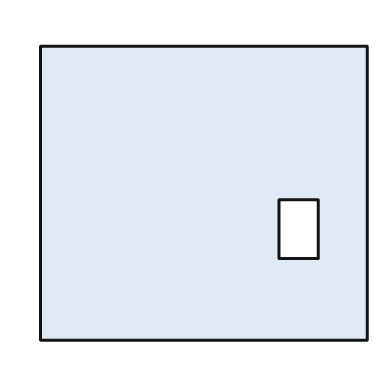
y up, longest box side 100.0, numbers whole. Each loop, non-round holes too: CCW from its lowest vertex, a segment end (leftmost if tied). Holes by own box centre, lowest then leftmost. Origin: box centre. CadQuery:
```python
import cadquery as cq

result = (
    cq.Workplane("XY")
    .moveTo(-50.0, -45.0)
    .lineTo(50.0, -45.0)
    .lineTo(50.0, 45.0)
    .lineTo(-50.0, 45.0)
    .close()
    .moveTo(23.0, -20.0)
    .lineTo(35.0, -20.0)
    .lineTo(35.0, -2.0)
    .lineTo(23.0, -2.0)
    .close()
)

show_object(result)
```